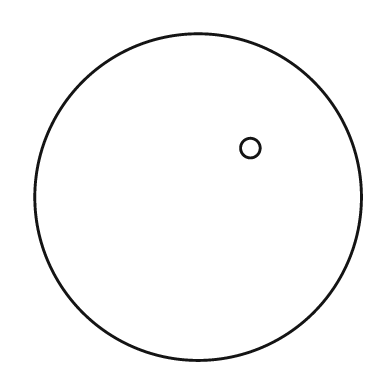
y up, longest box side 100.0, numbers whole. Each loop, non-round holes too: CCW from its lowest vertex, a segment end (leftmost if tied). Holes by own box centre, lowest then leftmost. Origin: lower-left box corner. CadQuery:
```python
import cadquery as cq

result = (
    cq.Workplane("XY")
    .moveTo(50.0, 50.0)
    .circle(50.0)
    .moveTo(66.0, 65.0)
    .circle(3.0)
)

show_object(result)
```